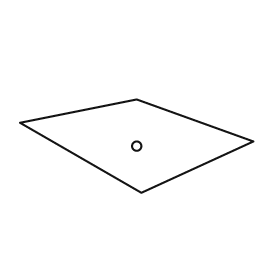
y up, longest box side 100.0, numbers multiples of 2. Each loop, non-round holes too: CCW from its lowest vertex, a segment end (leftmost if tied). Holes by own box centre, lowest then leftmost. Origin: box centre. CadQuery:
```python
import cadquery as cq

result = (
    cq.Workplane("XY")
    .moveTo(2.0, -20.0)
    .lineTo(50.0, 2.0)
    .lineTo(0.0, 20.0)
    .lineTo(-50.0, 10.0)
    .close()
    .moveTo(0.0, 0.0)
    .circle(2.0)
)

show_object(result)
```